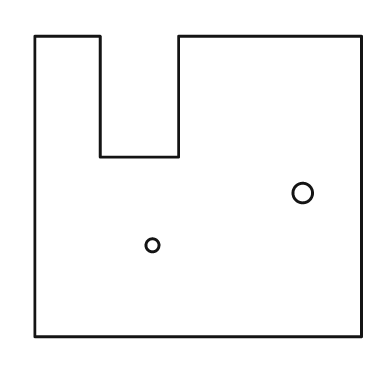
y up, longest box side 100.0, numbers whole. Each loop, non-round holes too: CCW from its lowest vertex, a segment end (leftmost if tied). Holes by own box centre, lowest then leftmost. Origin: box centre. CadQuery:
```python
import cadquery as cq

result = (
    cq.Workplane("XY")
    .moveTo(-50.0, -46.0)
    .lineTo(50.0, -46.0)
    .lineTo(50.0, 46.0)
    .lineTo(-6.0, 46.0)
    .lineTo(-6.0, 9.0)
    .lineTo(-30.0, 9.0)
    .lineTo(-30.0, 46.0)
    .lineTo(-50.0, 46.0)
    .close()
    .moveTo(-14.0, -18.0)
    .circle(2.0)
    .moveTo(32.0, -2.0)
    .circle(3.0)
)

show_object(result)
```